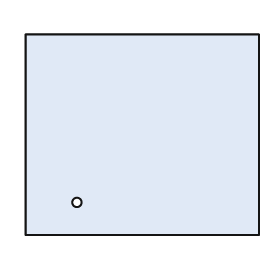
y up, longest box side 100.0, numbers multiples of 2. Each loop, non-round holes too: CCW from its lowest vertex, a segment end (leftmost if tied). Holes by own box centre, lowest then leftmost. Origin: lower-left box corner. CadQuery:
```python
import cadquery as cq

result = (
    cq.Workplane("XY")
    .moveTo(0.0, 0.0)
    .lineTo(100.0, 0.0)
    .lineTo(100.0, 86.0)
    .lineTo(0.0, 86.0)
    .close()
    .moveTo(22.0, 14.0)
    .circle(2.0)
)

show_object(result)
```